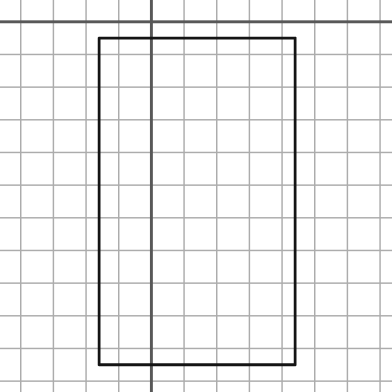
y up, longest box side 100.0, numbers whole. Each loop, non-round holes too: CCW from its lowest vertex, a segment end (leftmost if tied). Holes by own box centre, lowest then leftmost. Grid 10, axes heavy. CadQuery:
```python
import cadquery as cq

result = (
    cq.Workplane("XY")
    .moveTo(-16.0, -105.0)
    .lineTo(44.0, -105.0)
    .lineTo(44.0, -5.0)
    .lineTo(-16.0, -5.0)
    .close()
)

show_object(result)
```